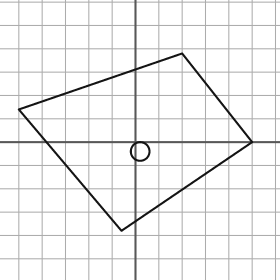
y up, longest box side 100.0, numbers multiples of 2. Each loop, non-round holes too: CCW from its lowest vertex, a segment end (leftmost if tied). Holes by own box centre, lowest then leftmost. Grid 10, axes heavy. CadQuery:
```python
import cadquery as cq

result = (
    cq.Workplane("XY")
    .moveTo(-6.0, -38.0)
    .lineTo(50.0, 0.0)
    .lineTo(20.0, 38.0)
    .lineTo(-50.0, 14.0)
    .close()
    .moveTo(2.0, -4.0)
    .circle(4.0)
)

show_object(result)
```